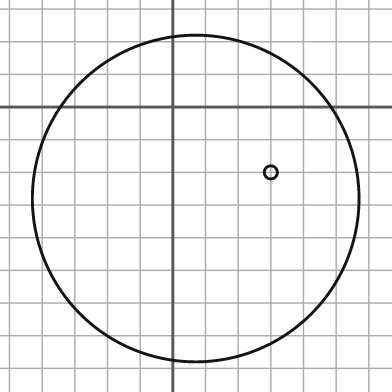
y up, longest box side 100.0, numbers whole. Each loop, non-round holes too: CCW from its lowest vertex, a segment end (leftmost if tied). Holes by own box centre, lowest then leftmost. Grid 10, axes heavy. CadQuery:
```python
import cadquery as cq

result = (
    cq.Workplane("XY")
    .moveTo(7.0, -28.0)
    .circle(50.0)
    .moveTo(30.0, -20.0)
    .circle(2.0)
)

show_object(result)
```